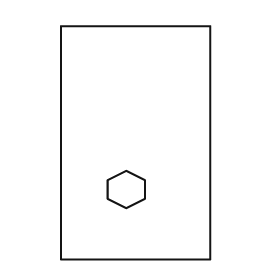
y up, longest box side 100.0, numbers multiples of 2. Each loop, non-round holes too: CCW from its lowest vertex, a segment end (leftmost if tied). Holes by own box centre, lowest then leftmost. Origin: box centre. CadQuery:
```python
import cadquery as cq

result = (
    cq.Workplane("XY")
    .moveTo(-32.0, -50.0)
    .lineTo(32.0, -50.0)
    .lineTo(32.0, 50.0)
    .lineTo(-32.0, 50.0)
    .close()
    .moveTo(-4.0, -28.0)
    .lineTo(4.0, -24.0)
    .lineTo(4.0, -16.0)
    .lineTo(-4.0, -12.0)
    .lineTo(-12.0, -16.0)
    .lineTo(-12.0, -24.0)
    .close()
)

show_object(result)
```